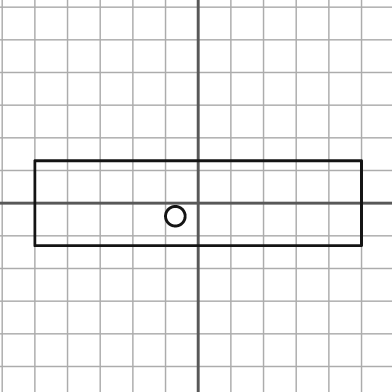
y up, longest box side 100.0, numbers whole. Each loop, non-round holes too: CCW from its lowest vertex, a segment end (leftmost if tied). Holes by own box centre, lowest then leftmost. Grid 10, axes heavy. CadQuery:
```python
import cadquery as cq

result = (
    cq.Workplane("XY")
    .moveTo(-50.0, -13.0)
    .lineTo(50.0, -13.0)
    .lineTo(50.0, 13.0)
    .lineTo(-50.0, 13.0)
    .close()
    .moveTo(-7.0, -4.0)
    .circle(3.0)
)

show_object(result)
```